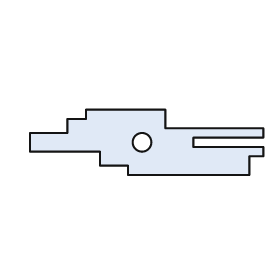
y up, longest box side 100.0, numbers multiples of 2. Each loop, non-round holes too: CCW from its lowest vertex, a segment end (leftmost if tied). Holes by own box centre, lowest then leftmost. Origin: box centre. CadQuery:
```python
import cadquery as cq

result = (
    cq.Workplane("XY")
    .moveTo(-8.0, -14.0)
    .lineTo(44.0, -14.0)
    .lineTo(44.0, -6.0)
    .lineTo(50.0, -6.0)
    .lineTo(50.0, -2.0)
    .lineTo(20.0, -2.0)
    .lineTo(20.0, 2.0)
    .lineTo(50.0, 2.0)
    .lineTo(50.0, 6.0)
    .lineTo(8.0, 6.0)
    .lineTo(8.0, 14.0)
    .lineTo(-26.0, 14.0)
    .lineTo(-26.0, 10.0)
    .lineTo(-34.0, 10.0)
    .lineTo(-34.0, 4.0)
    .lineTo(-50.0, 4.0)
    .lineTo(-50.0, -4.0)
    .lineTo(-20.0, -4.0)
    .lineTo(-20.0, -10.0)
    .lineTo(-8.0, -10.0)
    .close()
    .moveTo(-2.0, 0.0)
    .circle(4.0)
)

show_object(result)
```